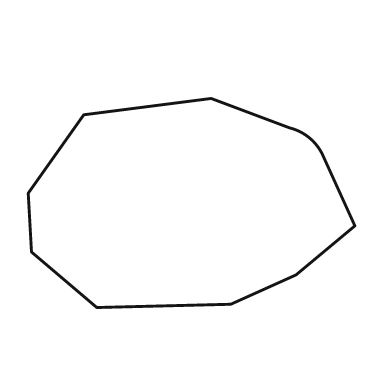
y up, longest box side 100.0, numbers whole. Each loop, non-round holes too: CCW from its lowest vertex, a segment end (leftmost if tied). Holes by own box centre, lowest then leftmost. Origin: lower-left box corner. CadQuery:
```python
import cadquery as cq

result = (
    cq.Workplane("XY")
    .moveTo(21.0, 0.0)
    .lineTo(62.0, 1.0)
    .lineTo(82.0, 10.0)
    .lineTo(100.0, 25.0)
    .lineTo(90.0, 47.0)
    .threePointArc((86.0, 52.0), (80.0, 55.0))
    .lineTo(56.0, 64.0)
    .lineTo(17.0, 59.0)
    .lineTo(0.0, 35.0)
    .lineTo(1.0, 17.0)
    .close()
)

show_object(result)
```